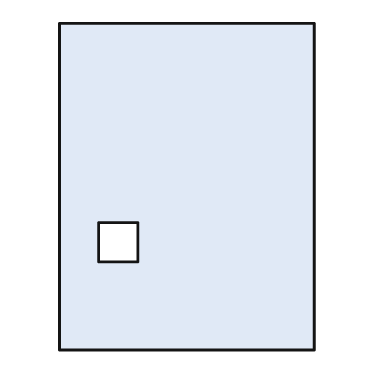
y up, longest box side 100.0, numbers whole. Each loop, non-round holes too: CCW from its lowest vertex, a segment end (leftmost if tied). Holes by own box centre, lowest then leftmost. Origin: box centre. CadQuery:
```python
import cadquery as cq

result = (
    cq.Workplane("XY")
    .moveTo(-39.0, -50.0)
    .lineTo(39.0, -50.0)
    .lineTo(39.0, 50.0)
    .lineTo(-39.0, 50.0)
    .close()
    .moveTo(-27.0, -23.0)
    .lineTo(-15.0, -23.0)
    .lineTo(-15.0, -11.0)
    .lineTo(-27.0, -11.0)
    .close()
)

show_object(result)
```